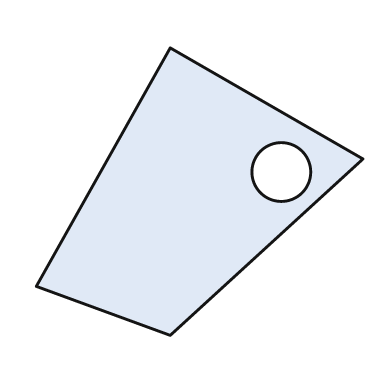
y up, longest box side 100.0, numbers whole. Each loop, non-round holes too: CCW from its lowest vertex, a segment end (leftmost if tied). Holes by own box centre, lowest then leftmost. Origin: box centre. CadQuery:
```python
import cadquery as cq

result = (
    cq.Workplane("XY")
    .moveTo(-9.0, -44.0)
    .lineTo(50.0, 10.0)
    .lineTo(-9.0, 44.0)
    .lineTo(-50.0, -29.0)
    .close()
    .moveTo(25.0, 6.0)
    .circle(9.0)
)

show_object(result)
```